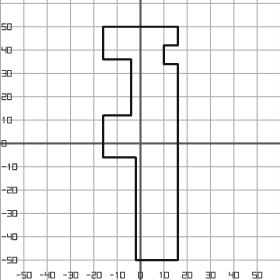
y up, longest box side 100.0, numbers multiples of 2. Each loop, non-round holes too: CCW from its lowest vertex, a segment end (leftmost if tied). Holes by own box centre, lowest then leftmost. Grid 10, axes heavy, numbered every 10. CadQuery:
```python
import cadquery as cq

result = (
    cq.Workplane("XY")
    .moveTo(-2.0, -50.0)
    .lineTo(16.0, -50.0)
    .lineTo(16.0, 34.0)
    .lineTo(10.0, 34.0)
    .lineTo(10.0, 42.0)
    .lineTo(16.0, 42.0)
    .lineTo(16.0, 50.0)
    .lineTo(-16.0, 50.0)
    .lineTo(-16.0, 36.0)
    .lineTo(-4.0, 36.0)
    .lineTo(-4.0, 12.0)
    .lineTo(-16.0, 12.0)
    .lineTo(-16.0, -6.0)
    .lineTo(-2.0, -6.0)
    .close()
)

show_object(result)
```